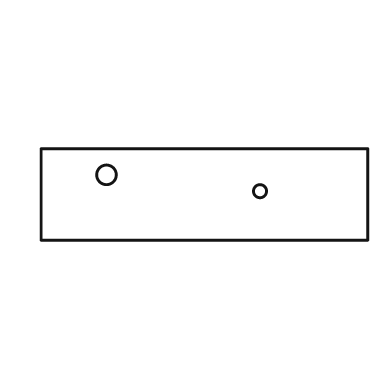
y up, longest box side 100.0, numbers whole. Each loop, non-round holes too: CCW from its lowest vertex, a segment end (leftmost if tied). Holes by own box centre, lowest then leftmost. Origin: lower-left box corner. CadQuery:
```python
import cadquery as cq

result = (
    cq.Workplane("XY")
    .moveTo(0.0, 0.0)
    .lineTo(100.0, 0.0)
    .lineTo(100.0, 28.0)
    .lineTo(0.0, 28.0)
    .close()
    .moveTo(67.0, 15.0)
    .circle(2.0)
    .moveTo(20.0, 20.0)
    .circle(3.0)
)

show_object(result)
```